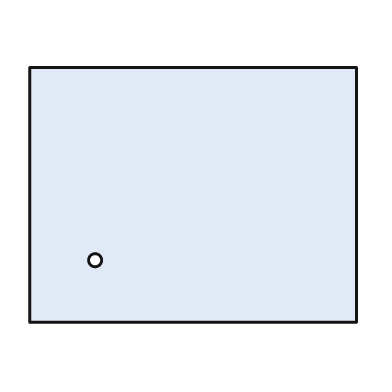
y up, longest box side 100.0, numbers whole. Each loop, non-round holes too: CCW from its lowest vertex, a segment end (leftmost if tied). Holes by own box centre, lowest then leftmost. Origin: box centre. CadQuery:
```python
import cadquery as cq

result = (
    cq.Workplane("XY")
    .moveTo(-50.0, -39.0)
    .lineTo(50.0, -39.0)
    .lineTo(50.0, 39.0)
    .lineTo(-50.0, 39.0)
    .close()
    .moveTo(-30.0, -20.0)
    .circle(2.0)
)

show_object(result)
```